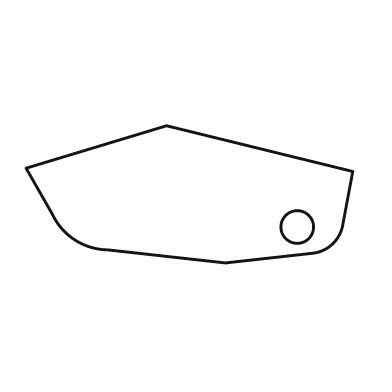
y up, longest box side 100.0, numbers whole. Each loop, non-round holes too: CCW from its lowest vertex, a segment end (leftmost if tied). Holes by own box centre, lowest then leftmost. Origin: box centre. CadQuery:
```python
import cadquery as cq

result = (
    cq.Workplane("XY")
    .moveTo(11.0, -21.0)
    .lineTo(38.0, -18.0)
    .threePointArc((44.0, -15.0), (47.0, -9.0))
    .lineTo(50.0, 7.0)
    .lineTo(-7.0, 21.0)
    .lineTo(-50.0, 8.0)
    .lineTo(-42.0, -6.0)
    .threePointArc((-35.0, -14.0), (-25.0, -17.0))
    .close()
    .moveTo(33.0, -10.0)
    .circle(5.0)
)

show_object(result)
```